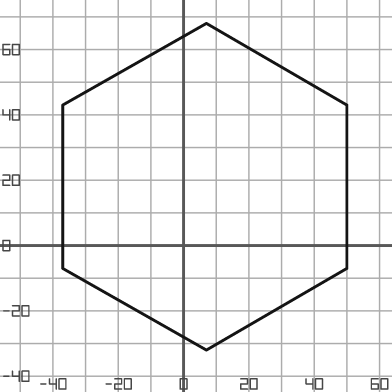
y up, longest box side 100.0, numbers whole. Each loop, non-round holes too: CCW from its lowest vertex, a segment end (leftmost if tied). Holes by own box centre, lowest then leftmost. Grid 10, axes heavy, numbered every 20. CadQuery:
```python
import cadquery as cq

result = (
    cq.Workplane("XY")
    .moveTo(7.0, -32.0)
    .lineTo(50.0, -7.0)
    .lineTo(50.0, 43.0)
    .lineTo(7.0, 68.0)
    .lineTo(-37.0, 43.0)
    .lineTo(-37.0, -7.0)
    .close()
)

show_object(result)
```